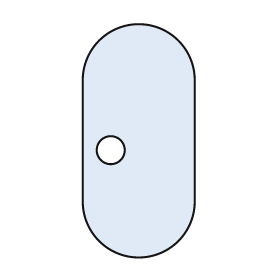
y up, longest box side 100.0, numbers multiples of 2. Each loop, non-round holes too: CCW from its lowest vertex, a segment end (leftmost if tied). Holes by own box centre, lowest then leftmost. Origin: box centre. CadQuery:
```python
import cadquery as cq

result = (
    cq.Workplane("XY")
    .moveTo(-24.0, -26.0)
    .threePointArc((0.0, -50.0), (24.0, -26.0))
    .lineTo(24.0, 26.0)
    .threePointArc((0.0, 50.0), (-24.0, 26.0))
    .close()
    .moveTo(-12.0, -4.0)
    .circle(6.0)
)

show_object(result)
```